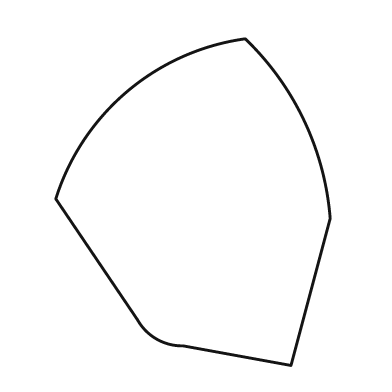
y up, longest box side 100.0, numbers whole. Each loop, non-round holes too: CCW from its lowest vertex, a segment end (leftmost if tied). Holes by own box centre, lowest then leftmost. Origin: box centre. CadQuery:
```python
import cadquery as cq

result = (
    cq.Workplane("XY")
    .moveTo(30.0, -50.0)
    .lineTo(42.0, -5.0)
    .threePointArc((34.0, 25.0), (16.0, 50.0))
    .threePointArc((-20.0, 34.0), (-42.0, 1.0))
    .lineTo(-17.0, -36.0)
    .threePointArc((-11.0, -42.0), (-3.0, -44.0))
    .close()
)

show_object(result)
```